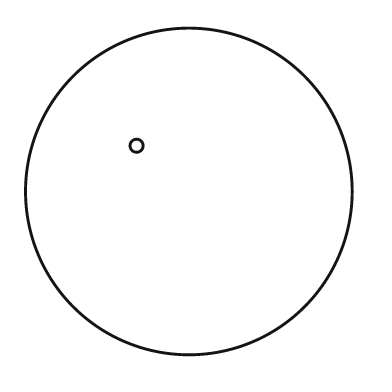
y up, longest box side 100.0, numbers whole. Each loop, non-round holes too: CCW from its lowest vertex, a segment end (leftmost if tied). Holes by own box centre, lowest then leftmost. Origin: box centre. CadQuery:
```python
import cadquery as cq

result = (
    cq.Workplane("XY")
    .moveTo(0.0, 0.0)
    .circle(50.0)
    .moveTo(-16.0, 14.0)
    .circle(2.0)
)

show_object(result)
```